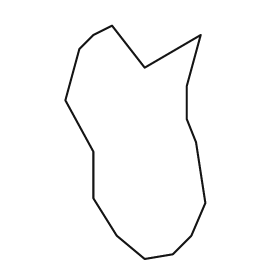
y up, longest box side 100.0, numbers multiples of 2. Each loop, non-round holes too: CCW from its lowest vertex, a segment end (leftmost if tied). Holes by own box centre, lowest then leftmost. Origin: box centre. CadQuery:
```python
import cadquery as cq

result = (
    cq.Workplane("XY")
    .moveTo(4.0, -50.0)
    .lineTo(16.0, -48.0)
    .lineTo(24.0, -40.0)
    .lineTo(30.0, -26.0)
    .lineTo(26.0, 0.0)
    .lineTo(22.0, 10.0)
    .lineTo(22.0, 24.0)
    .lineTo(28.0, 46.0)
    .lineTo(4.0, 32.0)
    .lineTo(-10.0, 50.0)
    .lineTo(-18.0, 46.0)
    .lineTo(-24.0, 40.0)
    .lineTo(-30.0, 18.0)
    .lineTo(-18.0, -4.0)
    .lineTo(-18.0, -24.0)
    .lineTo(-8.0, -40.0)
    .close()
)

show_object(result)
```